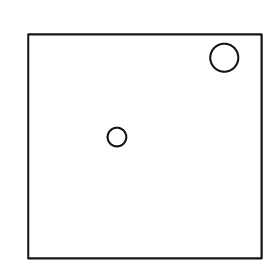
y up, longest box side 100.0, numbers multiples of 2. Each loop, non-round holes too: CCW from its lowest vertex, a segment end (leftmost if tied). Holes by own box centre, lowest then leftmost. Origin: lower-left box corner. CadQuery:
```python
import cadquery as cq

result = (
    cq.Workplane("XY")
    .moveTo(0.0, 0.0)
    .lineTo(100.0, 0.0)
    .lineTo(100.0, 96.0)
    .lineTo(0.0, 96.0)
    .close()
    .moveTo(38.0, 52.0)
    .circle(4.0)
    .moveTo(84.0, 86.0)
    .circle(6.0)
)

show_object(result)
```